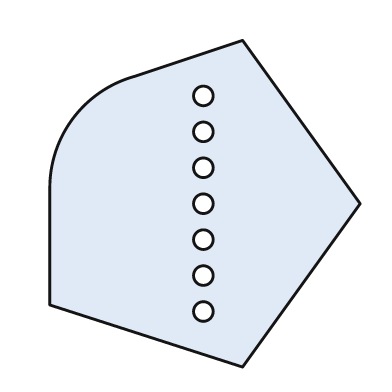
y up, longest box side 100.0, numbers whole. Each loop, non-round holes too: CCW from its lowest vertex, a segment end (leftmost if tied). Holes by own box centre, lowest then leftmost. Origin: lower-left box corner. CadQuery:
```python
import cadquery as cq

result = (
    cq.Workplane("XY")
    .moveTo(59.0, 0.0)
    .lineTo(95.0, 50.0)
    .lineTo(59.0, 100.0)
    .lineTo(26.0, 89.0)
    .threePointArc((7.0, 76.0), (0.0, 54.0))
    .lineTo(0.0, 19.0)
    .close()
    .moveTo(47.0, 17.0)
    .circle(3.0)
    .moveTo(47.0, 28.0)
    .circle(3.0)
    .moveTo(47.0, 39.0)
    .circle(3.0)
    .moveTo(47.0, 50.0)
    .circle(3.0)
    .moveTo(47.0, 61.0)
    .circle(3.0)
    .moveTo(47.0, 72.0)
    .circle(3.0)
    .moveTo(47.0, 83.0)
    .circle(3.0)
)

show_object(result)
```